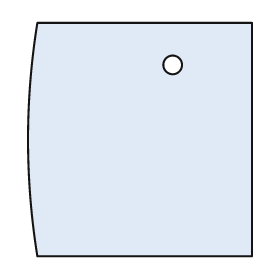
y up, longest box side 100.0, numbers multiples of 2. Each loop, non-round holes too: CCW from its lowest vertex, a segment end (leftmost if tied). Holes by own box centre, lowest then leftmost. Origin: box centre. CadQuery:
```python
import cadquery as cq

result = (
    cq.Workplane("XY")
    .moveTo(-44.0, -50.0)
    .lineTo(48.0, -50.0)
    .lineTo(48.0, 50.0)
    .lineTo(-44.0, 50.0)
    .threePointArc((-48.0, 0.0), (-44.0, -50.0))
    .close()
    .moveTo(14.0, 32.0)
    .circle(4.0)
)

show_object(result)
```